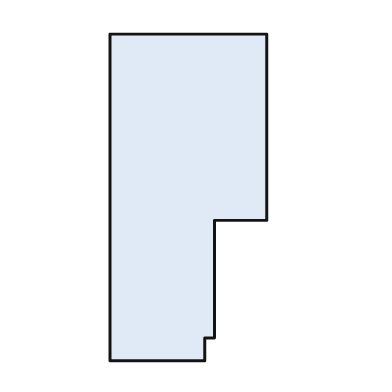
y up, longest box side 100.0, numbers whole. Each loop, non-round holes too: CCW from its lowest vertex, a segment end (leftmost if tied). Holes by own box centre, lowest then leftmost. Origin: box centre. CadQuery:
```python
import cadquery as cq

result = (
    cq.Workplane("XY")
    .moveTo(-24.0, -50.0)
    .lineTo(5.0, -50.0)
    .lineTo(5.0, -43.0)
    .lineTo(8.0, -43.0)
    .lineTo(8.0, -7.0)
    .lineTo(24.0, -7.0)
    .lineTo(24.0, 50.0)
    .lineTo(-24.0, 50.0)
    .close()
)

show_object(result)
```